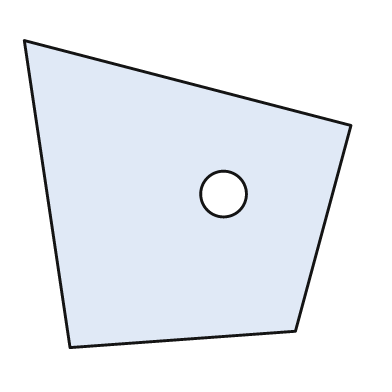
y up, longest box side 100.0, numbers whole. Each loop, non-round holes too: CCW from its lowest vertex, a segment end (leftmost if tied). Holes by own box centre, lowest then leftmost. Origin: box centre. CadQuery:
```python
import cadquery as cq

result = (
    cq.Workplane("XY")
    .moveTo(-36.0, -47.0)
    .lineTo(33.0, -42.0)
    .lineTo(50.0, 21.0)
    .lineTo(-50.0, 47.0)
    .close()
    .moveTo(11.0, 0.0)
    .circle(7.0)
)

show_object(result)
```